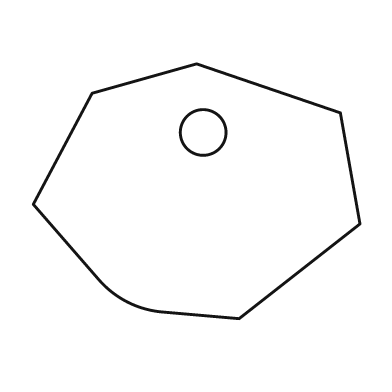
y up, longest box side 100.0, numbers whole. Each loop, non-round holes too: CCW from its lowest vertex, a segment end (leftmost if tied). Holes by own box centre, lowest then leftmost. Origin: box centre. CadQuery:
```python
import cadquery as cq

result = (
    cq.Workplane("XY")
    .moveTo(13.0, -39.0)
    .lineTo(50.0, -10.0)
    .lineTo(44.0, 24.0)
    .lineTo(0.0, 39.0)
    .lineTo(-32.0, 30.0)
    .lineTo(-50.0, -4.0)
    .lineTo(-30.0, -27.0)
    .threePointArc((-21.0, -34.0), (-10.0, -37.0))
    .close()
    .moveTo(2.0, 18.0)
    .circle(7.0)
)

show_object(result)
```